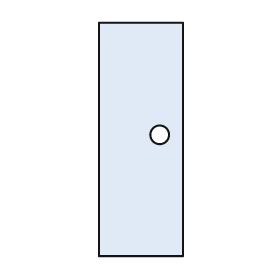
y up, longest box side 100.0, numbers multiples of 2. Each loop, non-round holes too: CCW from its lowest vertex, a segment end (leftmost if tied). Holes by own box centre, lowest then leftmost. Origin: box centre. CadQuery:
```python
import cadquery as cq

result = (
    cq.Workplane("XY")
    .moveTo(-18.0, -50.0)
    .lineTo(18.0, -50.0)
    .lineTo(18.0, 50.0)
    .lineTo(-18.0, 50.0)
    .close()
    .moveTo(8.0, 2.0)
    .circle(4.0)
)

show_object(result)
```